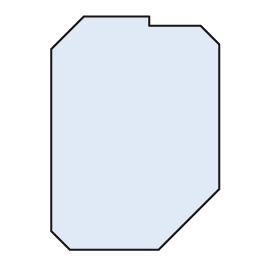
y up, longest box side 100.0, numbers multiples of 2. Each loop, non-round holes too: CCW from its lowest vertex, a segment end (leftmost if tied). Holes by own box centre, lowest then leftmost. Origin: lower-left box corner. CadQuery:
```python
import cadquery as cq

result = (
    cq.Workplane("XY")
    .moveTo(8.0, 0.0)
    .lineTo(46.0, 0.0)
    .lineTo(72.0, 26.0)
    .lineTo(72.0, 88.0)
    .lineTo(64.0, 96.0)
    .lineTo(42.0, 96.0)
    .lineTo(42.0, 100.0)
    .lineTo(14.0, 100.0)
    .lineTo(0.0, 86.0)
    .lineTo(0.0, 8.0)
    .close()
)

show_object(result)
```